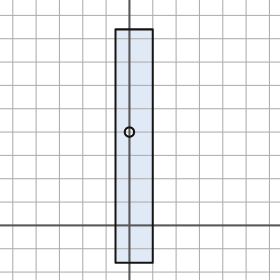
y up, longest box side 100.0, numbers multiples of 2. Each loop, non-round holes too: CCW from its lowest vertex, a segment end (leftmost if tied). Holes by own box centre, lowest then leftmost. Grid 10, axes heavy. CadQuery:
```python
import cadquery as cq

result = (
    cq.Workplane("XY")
    .moveTo(-6.0, -16.0)
    .lineTo(10.0, -16.0)
    .lineTo(10.0, 84.0)
    .lineTo(-6.0, 84.0)
    .close()
    .moveTo(0.0, 40.0)
    .circle(2.0)
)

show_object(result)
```